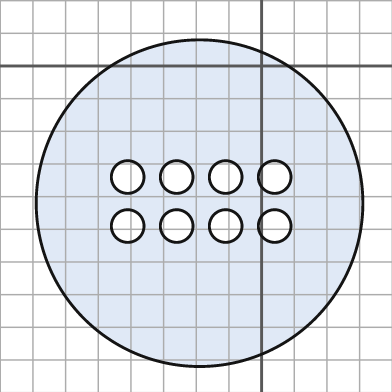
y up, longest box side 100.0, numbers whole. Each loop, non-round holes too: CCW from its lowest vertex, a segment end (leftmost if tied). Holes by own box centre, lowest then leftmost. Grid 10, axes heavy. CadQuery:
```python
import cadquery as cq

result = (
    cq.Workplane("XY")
    .moveTo(-19.0, -42.0)
    .circle(50.0)
    .moveTo(-41.0, -49.0)
    .circle(5.0)
    .moveTo(-26.0, -49.0)
    .circle(5.0)
    .moveTo(-11.0, -49.0)
    .circle(5.0)
    .moveTo(4.0, -49.0)
    .circle(5.0)
    .moveTo(-41.0, -34.0)
    .circle(5.0)
    .moveTo(-26.0, -34.0)
    .circle(5.0)
    .moveTo(-11.0, -34.0)
    .circle(5.0)
    .moveTo(4.0, -34.0)
    .circle(5.0)
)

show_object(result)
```